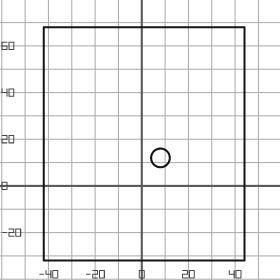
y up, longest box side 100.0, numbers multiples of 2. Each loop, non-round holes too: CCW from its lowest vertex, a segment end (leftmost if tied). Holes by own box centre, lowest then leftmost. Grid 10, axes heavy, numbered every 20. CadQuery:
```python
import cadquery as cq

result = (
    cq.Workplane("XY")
    .moveTo(-42.0, -32.0)
    .lineTo(44.0, -32.0)
    .lineTo(44.0, 68.0)
    .lineTo(-42.0, 68.0)
    .close()
    .moveTo(8.0, 12.0)
    .circle(4.0)
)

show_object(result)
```